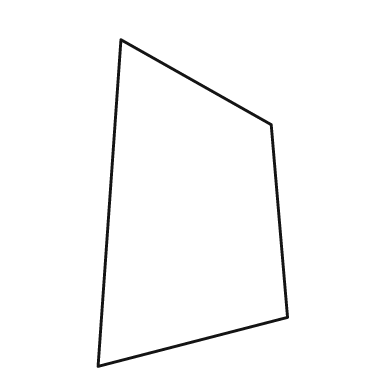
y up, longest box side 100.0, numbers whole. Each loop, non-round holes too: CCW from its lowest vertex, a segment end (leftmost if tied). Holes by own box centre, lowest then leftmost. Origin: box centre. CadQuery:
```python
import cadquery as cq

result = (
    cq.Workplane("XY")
    .moveTo(-29.0, -50.0)
    .lineTo(29.0, -35.0)
    .lineTo(24.0, 24.0)
    .lineTo(-22.0, 50.0)
    .close()
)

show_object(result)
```